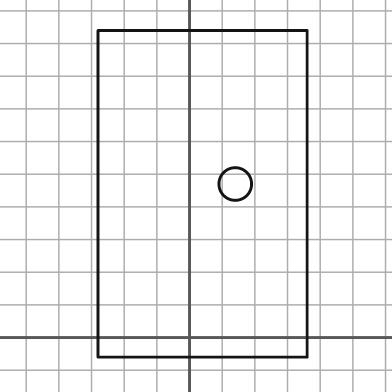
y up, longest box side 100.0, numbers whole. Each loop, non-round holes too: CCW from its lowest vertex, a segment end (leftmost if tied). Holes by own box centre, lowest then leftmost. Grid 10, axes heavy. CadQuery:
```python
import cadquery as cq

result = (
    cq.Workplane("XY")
    .moveTo(-28.0, -6.0)
    .lineTo(36.0, -6.0)
    .lineTo(36.0, 94.0)
    .lineTo(-28.0, 94.0)
    .close()
    .moveTo(14.0, 47.0)
    .circle(5.0)
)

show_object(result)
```